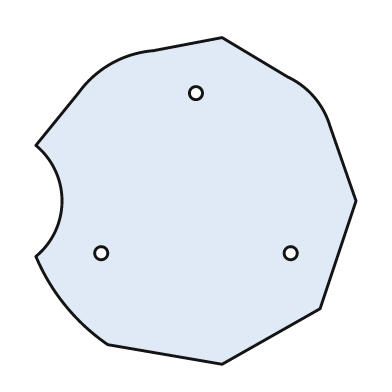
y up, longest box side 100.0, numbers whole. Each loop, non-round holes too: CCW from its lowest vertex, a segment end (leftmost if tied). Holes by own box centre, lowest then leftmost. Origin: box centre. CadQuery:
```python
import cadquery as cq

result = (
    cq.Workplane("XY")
    .moveTo(8.0, -50.0)
    .lineTo(38.0, -33.0)
    .lineTo(49.0, 0.0)
    .lineTo(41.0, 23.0)
    .threePointArc((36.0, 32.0), (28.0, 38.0))
    .lineTo(8.0, 50.0)
    .lineTo(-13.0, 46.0)
    .threePointArc((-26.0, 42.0), (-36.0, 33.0))
    .lineTo(-49.0, 17.0)
    .threePointArc((-41.0, 0.0), (-49.0, -17.0))
    .threePointArc((-40.0, -32.0), (-27.0, -44.0))
    .close()
    .moveTo(-29.0, -16.0)
    .circle(2.0)
    .moveTo(29.0, -16.0)
    .circle(2.0)
    .moveTo(0.0, 33.0)
    .circle(2.0)
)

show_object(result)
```